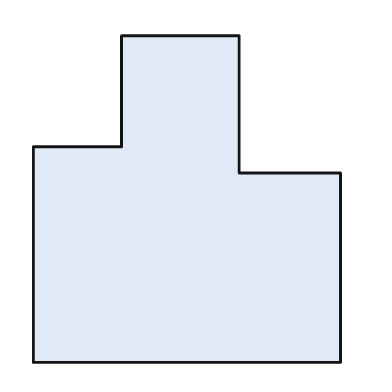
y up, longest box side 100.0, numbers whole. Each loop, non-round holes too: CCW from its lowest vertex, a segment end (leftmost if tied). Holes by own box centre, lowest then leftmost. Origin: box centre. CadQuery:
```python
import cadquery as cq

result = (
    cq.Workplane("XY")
    .moveTo(-47.0, -50.0)
    .lineTo(47.0, -50.0)
    .lineTo(47.0, 8.0)
    .lineTo(16.0, 8.0)
    .lineTo(16.0, 50.0)
    .lineTo(-20.0, 50.0)
    .lineTo(-20.0, 16.0)
    .lineTo(-47.0, 16.0)
    .close()
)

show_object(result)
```